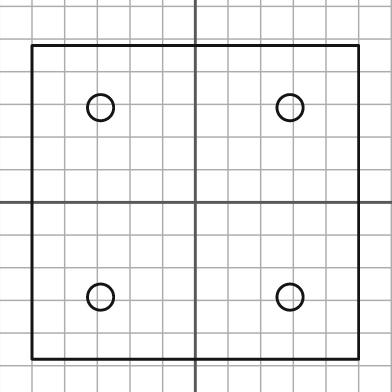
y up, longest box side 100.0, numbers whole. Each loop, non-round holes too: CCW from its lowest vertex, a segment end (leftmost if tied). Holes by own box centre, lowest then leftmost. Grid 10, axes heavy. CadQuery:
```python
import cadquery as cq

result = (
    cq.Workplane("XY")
    .moveTo(-50.0, -48.0)
    .lineTo(50.0, -48.0)
    .lineTo(50.0, 48.0)
    .lineTo(-50.0, 48.0)
    .close()
    .moveTo(-29.0, -29.0)
    .circle(4.0)
    .moveTo(29.0, -29.0)
    .circle(4.0)
    .moveTo(-29.0, 29.0)
    .circle(4.0)
    .moveTo(29.0, 29.0)
    .circle(4.0)
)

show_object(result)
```